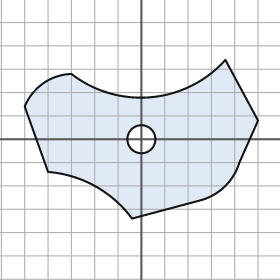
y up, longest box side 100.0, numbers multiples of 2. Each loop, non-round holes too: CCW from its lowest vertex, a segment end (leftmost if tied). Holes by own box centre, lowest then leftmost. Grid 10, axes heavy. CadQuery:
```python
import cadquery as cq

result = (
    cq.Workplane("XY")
    .moveTo(-4.0, -34.0)
    .lineTo(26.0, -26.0)
    .threePointArc((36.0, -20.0), (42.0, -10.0))
    .lineTo(50.0, 8.0)
    .lineTo(36.0, 34.0)
    .threePointArc((4.0, 18.0), (-30.0, 28.0))
    .threePointArc((-42.0, 24.0), (-50.0, 14.0))
    .lineTo(-40.0, -14.0)
    .threePointArc((-20.0, -20.0), (-4.0, -34.0))
    .close()
    .moveTo(0.0, 0.0)
    .circle(6.0)
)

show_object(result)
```